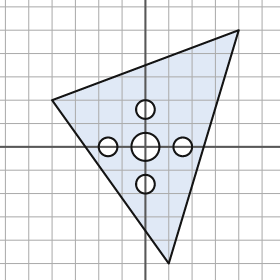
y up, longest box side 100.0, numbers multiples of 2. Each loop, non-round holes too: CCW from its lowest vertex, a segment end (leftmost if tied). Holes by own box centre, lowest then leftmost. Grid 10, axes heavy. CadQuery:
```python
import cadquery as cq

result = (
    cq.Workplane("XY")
    .moveTo(10.0, -50.0)
    .lineTo(40.0, 50.0)
    .lineTo(-40.0, 20.0)
    .close()
    .moveTo(0.0, -16.0)
    .circle(4.0)
    .moveTo(-16.0, 0.0)
    .circle(4.0)
    .moveTo(0.0, 0.0)
    .circle(6.0)
    .moveTo(16.0, 0.0)
    .circle(4.0)
    .moveTo(0.0, 16.0)
    .circle(4.0)
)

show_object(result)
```